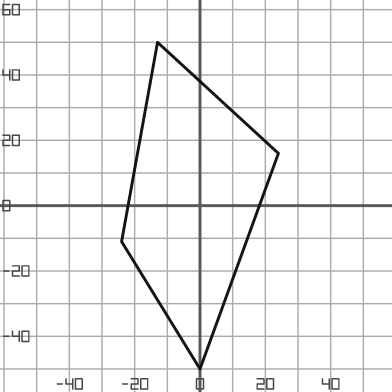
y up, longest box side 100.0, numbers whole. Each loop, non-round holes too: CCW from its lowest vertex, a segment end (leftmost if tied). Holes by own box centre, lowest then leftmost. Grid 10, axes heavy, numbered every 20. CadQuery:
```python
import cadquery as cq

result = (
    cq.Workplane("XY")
    .moveTo(0.0, -50.0)
    .lineTo(24.0, 16.0)
    .lineTo(-13.0, 50.0)
    .lineTo(-24.0, -11.0)
    .close()
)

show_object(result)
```